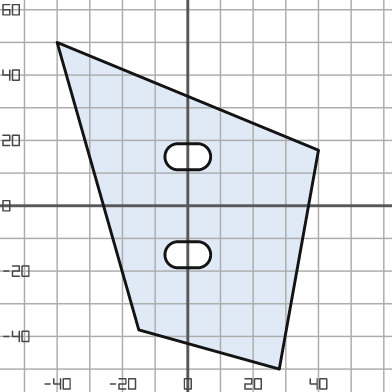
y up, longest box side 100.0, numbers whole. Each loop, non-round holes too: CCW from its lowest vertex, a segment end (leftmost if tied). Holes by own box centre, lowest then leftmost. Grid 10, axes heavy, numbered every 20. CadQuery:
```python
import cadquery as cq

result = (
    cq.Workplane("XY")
    .moveTo(28.0, -50.0)
    .lineTo(40.0, 17.0)
    .lineTo(-40.0, 50.0)
    .lineTo(-15.0, -38.0)
    .close()
    .moveTo(-3.0, -19.0)
    .lineTo(3.0, -19.0)
    .threePointArc((7.0, -15.0), (3.0, -11.0))
    .lineTo(-3.0, -11.0)
    .threePointArc((-7.0, -15.0), (-3.0, -19.0))
    .close()
    .moveTo(-3.0, 11.0)
    .lineTo(3.0, 11.0)
    .threePointArc((7.0, 15.0), (3.0, 19.0))
    .lineTo(-3.0, 19.0)
    .threePointArc((-7.0, 15.0), (-3.0, 11.0))
    .close()
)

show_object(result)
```